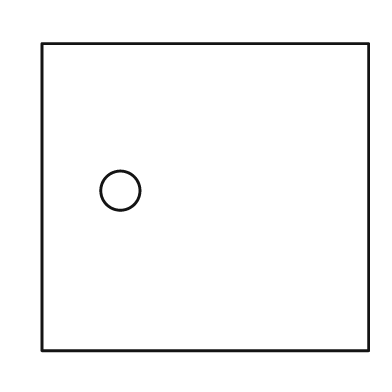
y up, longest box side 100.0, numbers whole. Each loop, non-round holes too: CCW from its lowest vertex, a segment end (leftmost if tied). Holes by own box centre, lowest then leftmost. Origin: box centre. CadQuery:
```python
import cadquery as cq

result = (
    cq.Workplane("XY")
    .moveTo(-50.0, -47.0)
    .lineTo(50.0, -47.0)
    .lineTo(50.0, 47.0)
    .lineTo(-50.0, 47.0)
    .close()
    .moveTo(-26.0, 2.0)
    .circle(6.0)
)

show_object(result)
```